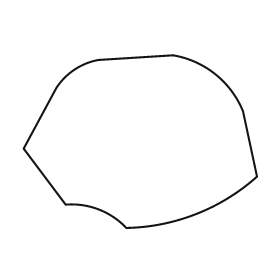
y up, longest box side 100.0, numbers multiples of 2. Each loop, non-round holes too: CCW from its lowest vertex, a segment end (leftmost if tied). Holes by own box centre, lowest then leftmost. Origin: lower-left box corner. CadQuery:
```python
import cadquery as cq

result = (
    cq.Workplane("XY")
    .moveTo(44.0, 0.0)
    .threePointArc((74.0, 6.0), (100.0, 22.0))
    .lineTo(94.0, 50.0)
    .threePointArc((82.0, 66.0), (64.0, 74.0))
    .lineTo(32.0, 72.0)
    .threePointArc((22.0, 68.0), (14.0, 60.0))
    .lineTo(0.0, 34.0)
    .lineTo(18.0, 10.0)
    .threePointArc((32.0, 8.0), (44.0, 0.0))
    .close()
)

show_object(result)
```